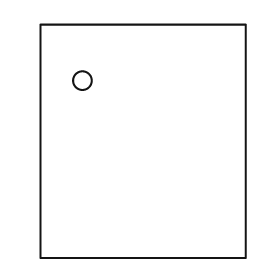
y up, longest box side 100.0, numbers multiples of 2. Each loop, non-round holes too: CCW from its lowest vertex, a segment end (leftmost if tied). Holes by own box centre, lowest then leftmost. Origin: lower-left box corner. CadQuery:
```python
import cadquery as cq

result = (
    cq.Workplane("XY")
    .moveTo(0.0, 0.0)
    .lineTo(88.0, 0.0)
    .lineTo(88.0, 100.0)
    .lineTo(0.0, 100.0)
    .close()
    .moveTo(18.0, 76.0)
    .circle(4.0)
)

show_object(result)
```